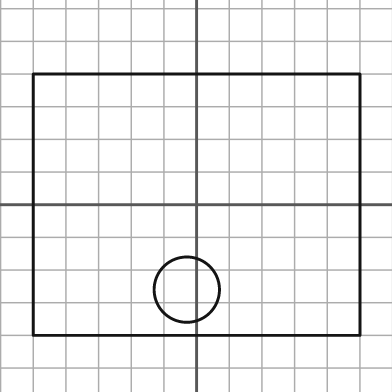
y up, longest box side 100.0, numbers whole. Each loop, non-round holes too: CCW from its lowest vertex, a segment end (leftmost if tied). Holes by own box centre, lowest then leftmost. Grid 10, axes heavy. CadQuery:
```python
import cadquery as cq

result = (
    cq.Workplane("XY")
    .moveTo(-50.0, -40.0)
    .lineTo(50.0, -40.0)
    .lineTo(50.0, 40.0)
    .lineTo(-50.0, 40.0)
    .close()
    .moveTo(-3.0, -26.0)
    .circle(10.0)
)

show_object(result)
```